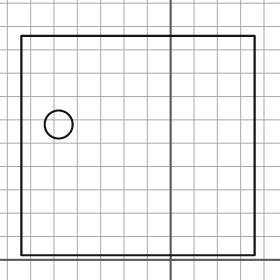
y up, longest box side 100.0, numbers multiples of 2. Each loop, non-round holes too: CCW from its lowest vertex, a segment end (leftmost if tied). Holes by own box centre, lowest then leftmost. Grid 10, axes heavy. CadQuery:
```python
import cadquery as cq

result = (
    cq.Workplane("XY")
    .moveTo(-64.0, 2.0)
    .lineTo(36.0, 2.0)
    .lineTo(36.0, 96.0)
    .lineTo(-64.0, 96.0)
    .close()
    .moveTo(-48.0, 58.0)
    .circle(6.0)
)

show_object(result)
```